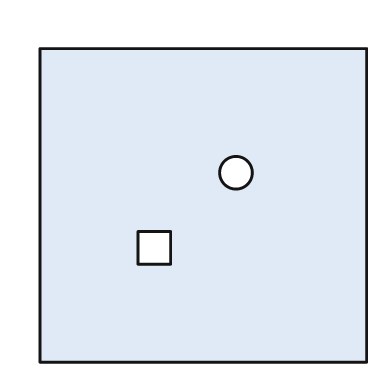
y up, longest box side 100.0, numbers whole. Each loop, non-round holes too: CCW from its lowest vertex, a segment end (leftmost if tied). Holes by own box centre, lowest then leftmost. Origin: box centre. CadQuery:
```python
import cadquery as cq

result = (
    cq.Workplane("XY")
    .moveTo(-50.0, -48.0)
    .lineTo(50.0, -48.0)
    .lineTo(50.0, 48.0)
    .lineTo(-50.0, 48.0)
    .close()
    .moveTo(-20.0, -18.0)
    .lineTo(-10.0, -18.0)
    .lineTo(-10.0, -8.0)
    .lineTo(-20.0, -8.0)
    .close()
    .moveTo(10.0, 10.0)
    .circle(5.0)
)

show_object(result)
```